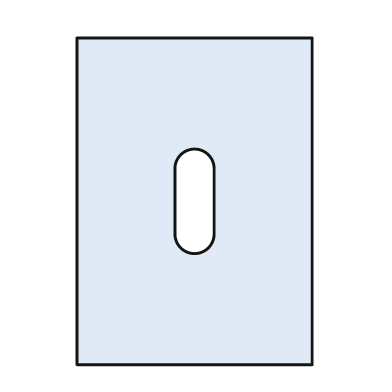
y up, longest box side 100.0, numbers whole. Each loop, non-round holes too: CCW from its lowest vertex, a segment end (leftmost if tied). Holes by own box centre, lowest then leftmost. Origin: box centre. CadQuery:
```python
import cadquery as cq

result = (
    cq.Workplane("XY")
    .moveTo(-36.0, -50.0)
    .lineTo(36.0, -50.0)
    .lineTo(36.0, 50.0)
    .lineTo(-36.0, 50.0)
    .close()
    .moveTo(-6.0, -10.0)
    .threePointArc((0.0, -16.0), (6.0, -10.0))
    .lineTo(6.0, 10.0)
    .threePointArc((0.0, 16.0), (-6.0, 10.0))
    .close()
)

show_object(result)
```